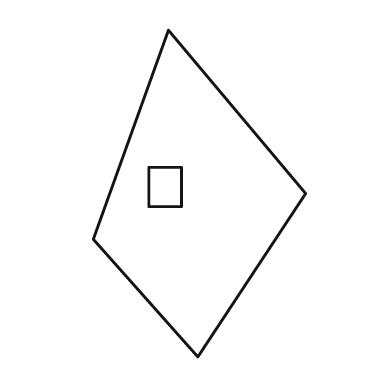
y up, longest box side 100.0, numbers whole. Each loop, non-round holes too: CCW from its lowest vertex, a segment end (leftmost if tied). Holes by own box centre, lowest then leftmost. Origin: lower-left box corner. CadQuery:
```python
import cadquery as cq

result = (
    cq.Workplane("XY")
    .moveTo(32.0, 0.0)
    .lineTo(65.0, 50.0)
    .lineTo(23.0, 100.0)
    .lineTo(0.0, 36.0)
    .close()
    .moveTo(17.0, 46.0)
    .lineTo(27.0, 46.0)
    .lineTo(27.0, 58.0)
    .lineTo(17.0, 58.0)
    .close()
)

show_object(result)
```